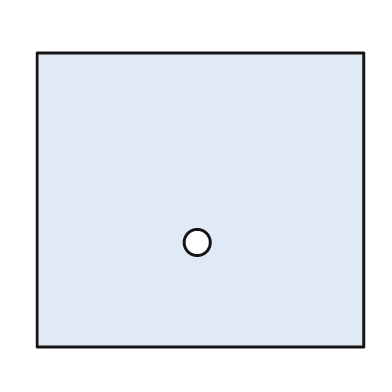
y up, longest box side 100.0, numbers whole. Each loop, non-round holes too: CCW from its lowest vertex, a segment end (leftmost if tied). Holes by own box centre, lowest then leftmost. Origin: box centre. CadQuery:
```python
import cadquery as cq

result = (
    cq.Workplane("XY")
    .moveTo(-50.0, -45.0)
    .lineTo(50.0, -45.0)
    .lineTo(50.0, 45.0)
    .lineTo(-50.0, 45.0)
    .close()
    .moveTo(-1.0, -13.0)
    .circle(4.0)
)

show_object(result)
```